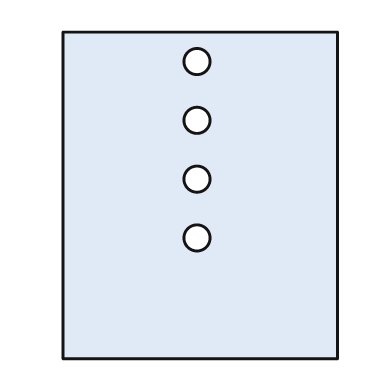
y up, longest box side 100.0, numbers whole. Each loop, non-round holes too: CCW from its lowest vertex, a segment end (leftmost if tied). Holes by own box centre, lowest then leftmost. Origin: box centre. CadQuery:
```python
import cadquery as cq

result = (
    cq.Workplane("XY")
    .moveTo(-42.0, -50.0)
    .lineTo(42.0, -50.0)
    .lineTo(42.0, 50.0)
    .lineTo(-42.0, 50.0)
    .close()
    .moveTo(-1.0, -13.0)
    .circle(4.0)
    .moveTo(-1.0, 5.0)
    .circle(4.0)
    .moveTo(-1.0, 23.0)
    .circle(4.0)
    .moveTo(-1.0, 41.0)
    .circle(4.0)
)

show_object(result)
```